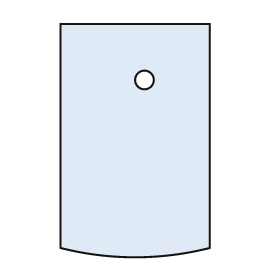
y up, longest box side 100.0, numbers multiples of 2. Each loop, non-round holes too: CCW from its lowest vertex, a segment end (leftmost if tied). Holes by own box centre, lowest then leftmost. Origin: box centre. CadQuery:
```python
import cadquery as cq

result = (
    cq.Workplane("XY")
    .moveTo(-32.0, -46.0)
    .threePointArc((0.0, -50.0), (32.0, -46.0))
    .lineTo(32.0, 50.0)
    .lineTo(-32.0, 50.0)
    .close()
    .moveTo(4.0, 26.0)
    .circle(4.0)
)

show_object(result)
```